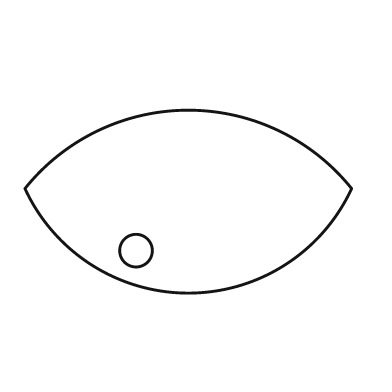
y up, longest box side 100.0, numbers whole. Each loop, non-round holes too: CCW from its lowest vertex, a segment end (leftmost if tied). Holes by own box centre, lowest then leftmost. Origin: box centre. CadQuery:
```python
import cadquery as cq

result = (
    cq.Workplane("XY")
    .moveTo(-50.0, 4.0)
    .threePointArc((0.0, -28.0), (50.0, 4.0))
    .threePointArc((0.0, 28.0), (-50.0, 4.0))
    .close()
    .moveTo(-16.0, -15.0)
    .circle(5.0)
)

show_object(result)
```